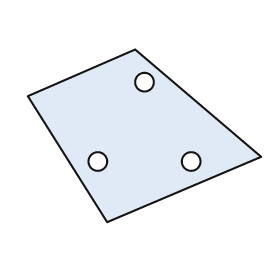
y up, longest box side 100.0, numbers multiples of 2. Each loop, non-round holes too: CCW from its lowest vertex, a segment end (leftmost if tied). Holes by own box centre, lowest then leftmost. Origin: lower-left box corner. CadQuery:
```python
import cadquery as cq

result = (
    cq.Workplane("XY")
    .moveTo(34.0, 0.0)
    .lineTo(100.0, 28.0)
    .lineTo(46.0, 74.0)
    .lineTo(0.0, 54.0)
    .close()
    .moveTo(30.0, 26.0)
    .circle(4.0)
    .moveTo(70.0, 26.0)
    .circle(4.0)
    .moveTo(50.0, 60.0)
    .circle(4.0)
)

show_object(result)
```